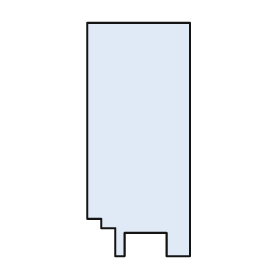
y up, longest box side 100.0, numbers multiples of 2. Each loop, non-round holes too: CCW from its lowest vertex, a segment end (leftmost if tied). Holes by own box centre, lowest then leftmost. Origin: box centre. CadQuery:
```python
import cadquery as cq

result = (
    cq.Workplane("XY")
    .moveTo(-10.0, -50.0)
    .lineTo(-6.0, -50.0)
    .lineTo(-6.0, -40.0)
    .lineTo(12.0, -40.0)
    .lineTo(12.0, -50.0)
    .lineTo(22.0, -50.0)
    .lineTo(22.0, 50.0)
    .lineTo(-22.0, 50.0)
    .lineTo(-22.0, -34.0)
    .lineTo(-16.0, -34.0)
    .lineTo(-16.0, -38.0)
    .lineTo(-10.0, -38.0)
    .close()
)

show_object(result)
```